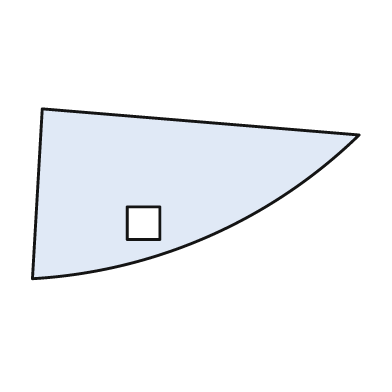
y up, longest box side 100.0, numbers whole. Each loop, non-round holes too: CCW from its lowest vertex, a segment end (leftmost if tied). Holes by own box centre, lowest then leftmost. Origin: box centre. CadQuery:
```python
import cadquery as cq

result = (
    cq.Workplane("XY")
    .moveTo(-50.0, -26.0)
    .threePointArc((4.0, -13.0), (50.0, 18.0))
    .lineTo(-47.0, 26.0)
    .close()
    .moveTo(-21.0, -14.0)
    .lineTo(-11.0, -14.0)
    .lineTo(-11.0, -4.0)
    .lineTo(-21.0, -4.0)
    .close()
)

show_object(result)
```